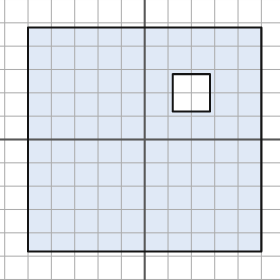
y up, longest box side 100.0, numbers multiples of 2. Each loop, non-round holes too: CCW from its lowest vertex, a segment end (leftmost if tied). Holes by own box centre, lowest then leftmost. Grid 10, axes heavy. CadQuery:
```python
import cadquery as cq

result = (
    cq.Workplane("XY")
    .moveTo(-50.0, -48.0)
    .lineTo(50.0, -48.0)
    .lineTo(50.0, 48.0)
    .lineTo(-50.0, 48.0)
    .close()
    .moveTo(12.0, 12.0)
    .lineTo(28.0, 12.0)
    .lineTo(28.0, 28.0)
    .lineTo(12.0, 28.0)
    .close()
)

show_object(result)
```